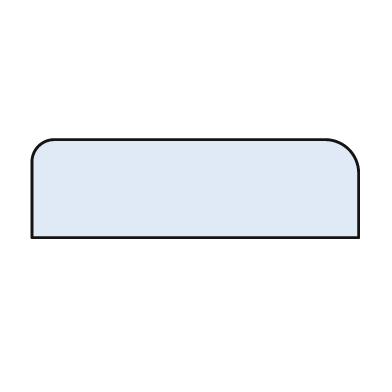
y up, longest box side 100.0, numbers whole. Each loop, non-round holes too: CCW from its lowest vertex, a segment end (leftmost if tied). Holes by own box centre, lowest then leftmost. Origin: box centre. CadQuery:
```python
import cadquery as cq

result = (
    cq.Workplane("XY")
    .moveTo(-50.0, -15.0)
    .lineTo(50.0, -15.0)
    .lineTo(50.0, 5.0)
    .threePointArc((47.0, 12.0), (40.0, 15.0))
    .lineTo(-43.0, 15.0)
    .threePointArc((-48.0, 13.0), (-50.0, 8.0))
    .close()
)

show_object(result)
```